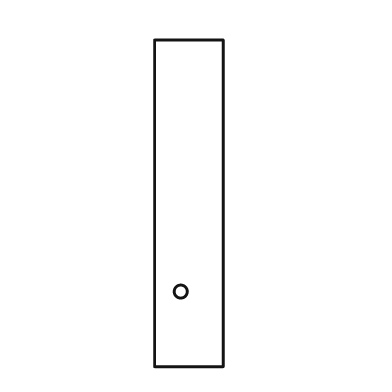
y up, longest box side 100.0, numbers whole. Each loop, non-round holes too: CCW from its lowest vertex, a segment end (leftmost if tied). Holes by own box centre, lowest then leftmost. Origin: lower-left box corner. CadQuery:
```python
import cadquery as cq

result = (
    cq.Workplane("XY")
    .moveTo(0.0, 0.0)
    .lineTo(21.0, 0.0)
    .lineTo(21.0, 100.0)
    .lineTo(0.0, 100.0)
    .close()
    .moveTo(8.0, 23.0)
    .circle(2.0)
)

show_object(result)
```